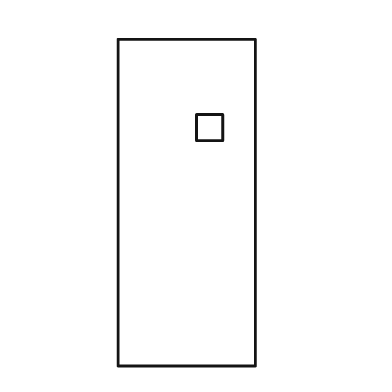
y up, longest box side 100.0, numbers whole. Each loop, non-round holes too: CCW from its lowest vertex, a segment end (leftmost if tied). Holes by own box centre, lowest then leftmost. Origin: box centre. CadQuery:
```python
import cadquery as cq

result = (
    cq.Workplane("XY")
    .moveTo(-21.0, -50.0)
    .lineTo(21.0, -50.0)
    .lineTo(21.0, 50.0)
    .lineTo(-21.0, 50.0)
    .close()
    .moveTo(3.0, 19.0)
    .lineTo(11.0, 19.0)
    .lineTo(11.0, 27.0)
    .lineTo(3.0, 27.0)
    .close()
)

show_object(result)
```